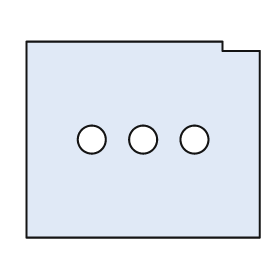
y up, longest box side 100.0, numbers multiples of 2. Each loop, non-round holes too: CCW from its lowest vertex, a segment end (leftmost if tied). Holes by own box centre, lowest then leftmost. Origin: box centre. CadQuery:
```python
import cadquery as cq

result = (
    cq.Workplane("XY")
    .moveTo(-50.0, -42.0)
    .lineTo(50.0, -42.0)
    .lineTo(50.0, 38.0)
    .lineTo(34.0, 38.0)
    .lineTo(34.0, 42.0)
    .lineTo(-50.0, 42.0)
    .close()
    .moveTo(-22.0, 0.0)
    .circle(6.0)
    .moveTo(0.0, 0.0)
    .circle(6.0)
    .moveTo(22.0, 0.0)
    .circle(6.0)
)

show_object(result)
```